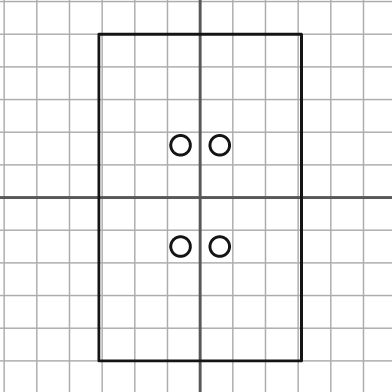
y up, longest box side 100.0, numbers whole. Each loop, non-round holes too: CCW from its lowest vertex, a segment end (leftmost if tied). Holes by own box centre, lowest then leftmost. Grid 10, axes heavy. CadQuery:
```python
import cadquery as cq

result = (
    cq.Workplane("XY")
    .moveTo(-31.0, -50.0)
    .lineTo(31.0, -50.0)
    .lineTo(31.0, 50.0)
    .lineTo(-31.0, 50.0)
    .close()
    .moveTo(-6.0, -15.0)
    .circle(3.0)
    .moveTo(6.0, -15.0)
    .circle(3.0)
    .moveTo(-6.0, 16.0)
    .circle(3.0)
    .moveTo(6.0, 16.0)
    .circle(3.0)
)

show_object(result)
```